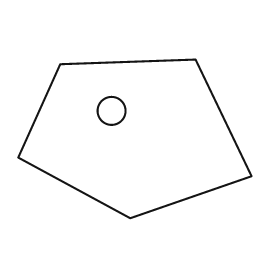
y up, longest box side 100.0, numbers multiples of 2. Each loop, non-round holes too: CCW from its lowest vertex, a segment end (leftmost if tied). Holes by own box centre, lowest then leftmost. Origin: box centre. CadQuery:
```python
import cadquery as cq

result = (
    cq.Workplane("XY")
    .moveTo(-2.0, -34.0)
    .lineTo(50.0, -16.0)
    .lineTo(26.0, 34.0)
    .lineTo(-32.0, 32.0)
    .lineTo(-50.0, -8.0)
    .close()
    .moveTo(-10.0, 12.0)
    .circle(6.0)
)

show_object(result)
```